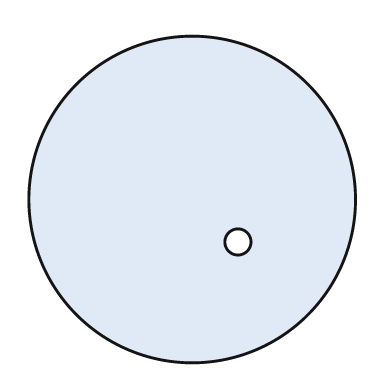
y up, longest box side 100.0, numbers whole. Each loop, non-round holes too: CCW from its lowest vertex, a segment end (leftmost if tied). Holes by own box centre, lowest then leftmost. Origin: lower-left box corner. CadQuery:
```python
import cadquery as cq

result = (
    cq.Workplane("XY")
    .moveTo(50.0, 50.0)
    .circle(50.0)
    .moveTo(64.0, 37.0)
    .circle(4.0)
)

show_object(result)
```